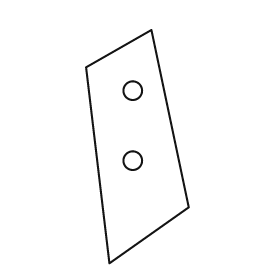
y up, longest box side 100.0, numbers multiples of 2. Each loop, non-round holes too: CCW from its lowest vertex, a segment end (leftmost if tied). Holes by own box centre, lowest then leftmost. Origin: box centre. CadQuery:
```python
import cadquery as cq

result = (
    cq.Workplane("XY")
    .moveTo(-12.0, -50.0)
    .lineTo(22.0, -26.0)
    .lineTo(6.0, 50.0)
    .lineTo(-22.0, 34.0)
    .close()
    .moveTo(-2.0, -6.0)
    .circle(4.0)
    .moveTo(-2.0, 24.0)
    .circle(4.0)
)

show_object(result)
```